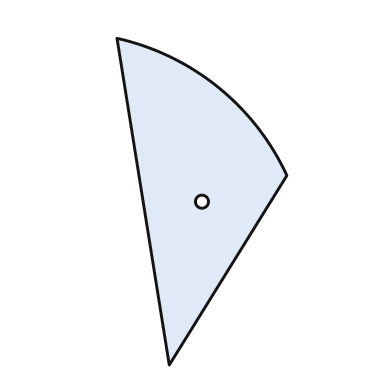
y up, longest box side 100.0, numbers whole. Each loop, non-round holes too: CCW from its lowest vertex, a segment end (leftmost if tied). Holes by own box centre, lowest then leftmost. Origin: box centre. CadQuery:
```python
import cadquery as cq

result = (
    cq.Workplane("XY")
    .moveTo(-10.0, -50.0)
    .lineTo(26.0, 8.0)
    .threePointArc((5.0, 35.0), (-26.0, 50.0))
    .close()
    .moveTo(0.0, 0.0)
    .circle(2.0)
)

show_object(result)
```